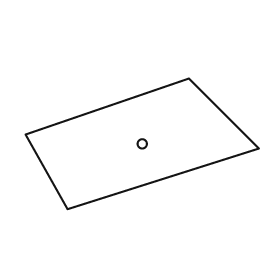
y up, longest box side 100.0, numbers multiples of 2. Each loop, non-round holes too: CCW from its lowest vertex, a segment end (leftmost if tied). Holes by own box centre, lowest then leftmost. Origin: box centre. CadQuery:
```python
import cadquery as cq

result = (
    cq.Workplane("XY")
    .moveTo(-32.0, -28.0)
    .lineTo(50.0, -2.0)
    .lineTo(20.0, 28.0)
    .lineTo(-50.0, 4.0)
    .close()
    .moveTo(0.0, 0.0)
    .circle(2.0)
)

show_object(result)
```